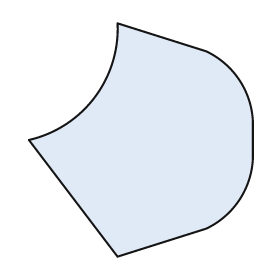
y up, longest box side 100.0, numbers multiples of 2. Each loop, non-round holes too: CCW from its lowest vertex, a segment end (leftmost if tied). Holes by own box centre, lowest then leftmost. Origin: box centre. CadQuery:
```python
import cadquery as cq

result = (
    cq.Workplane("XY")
    .moveTo(-10.0, -50.0)
    .lineTo(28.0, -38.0)
    .threePointArc((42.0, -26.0), (48.0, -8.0))
    .lineTo(48.0, 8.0)
    .threePointArc((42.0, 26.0), (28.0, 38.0))
    .lineTo(-10.0, 50.0)
    .threePointArc((-20.0, 18.0), (-48.0, 0.0))
    .close()
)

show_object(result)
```